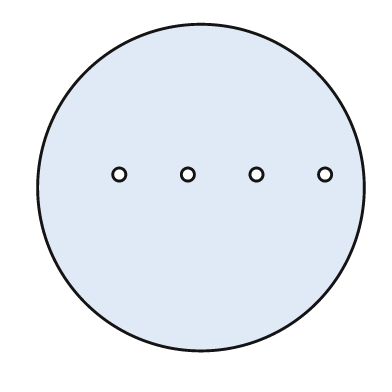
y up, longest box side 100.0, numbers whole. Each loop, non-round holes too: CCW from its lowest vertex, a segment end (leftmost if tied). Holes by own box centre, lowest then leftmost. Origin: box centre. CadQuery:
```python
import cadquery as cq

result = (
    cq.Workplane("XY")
    .moveTo(0.0, 0.0)
    .circle(50.0)
    .moveTo(-25.0, 4.0)
    .circle(2.0)
    .moveTo(-4.0, 4.0)
    .circle(2.0)
    .moveTo(17.0, 4.0)
    .circle(2.0)
    .moveTo(38.0, 4.0)
    .circle(2.0)
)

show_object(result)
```